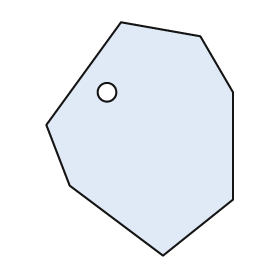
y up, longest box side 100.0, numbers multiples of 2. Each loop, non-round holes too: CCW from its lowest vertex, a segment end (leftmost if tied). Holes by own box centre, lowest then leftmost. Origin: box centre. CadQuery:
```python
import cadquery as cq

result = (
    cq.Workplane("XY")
    .moveTo(10.0, -50.0)
    .lineTo(40.0, -26.0)
    .lineTo(40.0, 20.0)
    .lineTo(26.0, 44.0)
    .lineTo(-8.0, 50.0)
    .lineTo(-40.0, 6.0)
    .lineTo(-30.0, -20.0)
    .close()
    .moveTo(-14.0, 20.0)
    .circle(4.0)
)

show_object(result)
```